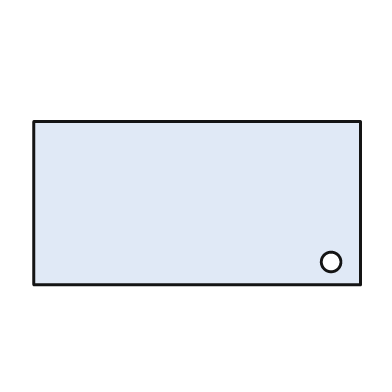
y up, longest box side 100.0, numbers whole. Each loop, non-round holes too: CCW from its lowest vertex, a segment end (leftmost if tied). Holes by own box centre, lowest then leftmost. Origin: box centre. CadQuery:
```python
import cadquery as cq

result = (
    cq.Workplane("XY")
    .moveTo(-50.0, -25.0)
    .lineTo(50.0, -25.0)
    .lineTo(50.0, 25.0)
    .lineTo(-50.0, 25.0)
    .close()
    .moveTo(41.0, -18.0)
    .circle(3.0)
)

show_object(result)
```